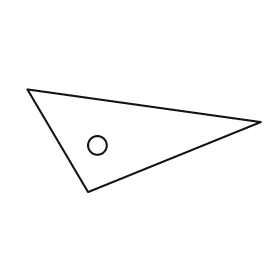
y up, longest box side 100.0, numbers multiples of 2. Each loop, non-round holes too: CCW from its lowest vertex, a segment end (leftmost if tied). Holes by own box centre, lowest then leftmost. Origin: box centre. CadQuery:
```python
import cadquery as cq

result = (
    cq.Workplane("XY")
    .moveTo(-24.0, -22.0)
    .lineTo(50.0, 8.0)
    .lineTo(-50.0, 22.0)
    .close()
    .moveTo(-20.0, -2.0)
    .circle(4.0)
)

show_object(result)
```